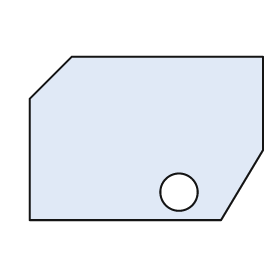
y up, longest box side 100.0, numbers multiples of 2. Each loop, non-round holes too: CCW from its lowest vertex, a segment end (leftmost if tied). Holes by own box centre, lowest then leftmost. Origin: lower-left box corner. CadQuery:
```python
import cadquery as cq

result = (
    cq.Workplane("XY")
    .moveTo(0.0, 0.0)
    .lineTo(82.0, 0.0)
    .lineTo(100.0, 30.0)
    .lineTo(100.0, 70.0)
    .lineTo(18.0, 70.0)
    .lineTo(0.0, 52.0)
    .close()
    .moveTo(64.0, 12.0)
    .circle(8.0)
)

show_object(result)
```